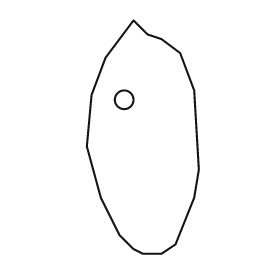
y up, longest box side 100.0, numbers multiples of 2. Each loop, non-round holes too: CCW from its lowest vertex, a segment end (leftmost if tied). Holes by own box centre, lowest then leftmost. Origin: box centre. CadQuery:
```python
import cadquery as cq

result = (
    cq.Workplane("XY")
    .moveTo(0.0, -50.0)
    .lineTo(8.0, -50.0)
    .lineTo(14.0, -46.0)
    .lineTo(22.0, -26.0)
    .lineTo(24.0, -14.0)
    .lineTo(22.0, 20.0)
    .lineTo(16.0, 36.0)
    .lineTo(8.0, 42.0)
    .lineTo(2.0, 44.0)
    .lineTo(-4.0, 50.0)
    .lineTo(-16.0, 34.0)
    .lineTo(-22.0, 18.0)
    .lineTo(-24.0, -4.0)
    .lineTo(-18.0, -26.0)
    .lineTo(-10.0, -42.0)
    .lineTo(-4.0, -48.0)
    .close()
    .moveTo(-8.0, 16.0)
    .circle(4.0)
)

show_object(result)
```